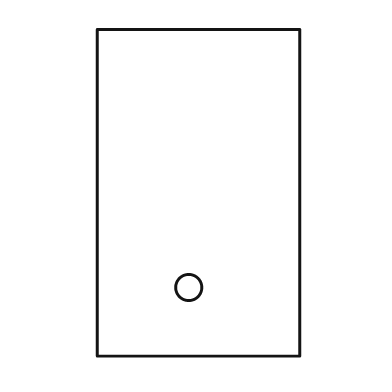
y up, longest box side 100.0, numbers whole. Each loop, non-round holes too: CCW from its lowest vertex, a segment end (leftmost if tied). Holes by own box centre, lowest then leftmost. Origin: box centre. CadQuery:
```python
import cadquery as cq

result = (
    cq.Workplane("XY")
    .moveTo(-31.0, -50.0)
    .lineTo(31.0, -50.0)
    .lineTo(31.0, 50.0)
    .lineTo(-31.0, 50.0)
    .close()
    .moveTo(-3.0, -29.0)
    .circle(4.0)
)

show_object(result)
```